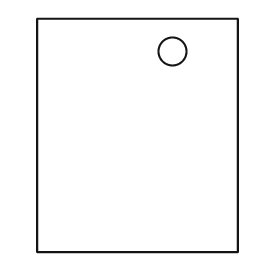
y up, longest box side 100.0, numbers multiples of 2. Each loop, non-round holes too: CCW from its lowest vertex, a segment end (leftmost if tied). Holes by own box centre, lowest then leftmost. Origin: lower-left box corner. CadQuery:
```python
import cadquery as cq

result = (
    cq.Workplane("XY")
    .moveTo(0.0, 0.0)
    .lineTo(86.0, 0.0)
    .lineTo(86.0, 100.0)
    .lineTo(0.0, 100.0)
    .close()
    .moveTo(58.0, 86.0)
    .circle(6.0)
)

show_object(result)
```